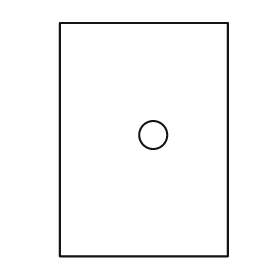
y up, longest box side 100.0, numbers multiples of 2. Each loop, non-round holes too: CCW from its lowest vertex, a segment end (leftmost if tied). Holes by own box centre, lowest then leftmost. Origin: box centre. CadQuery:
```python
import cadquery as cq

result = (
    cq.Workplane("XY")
    .moveTo(-36.0, -50.0)
    .lineTo(36.0, -50.0)
    .lineTo(36.0, 50.0)
    .lineTo(-36.0, 50.0)
    .close()
    .moveTo(4.0, 2.0)
    .circle(6.0)
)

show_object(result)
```